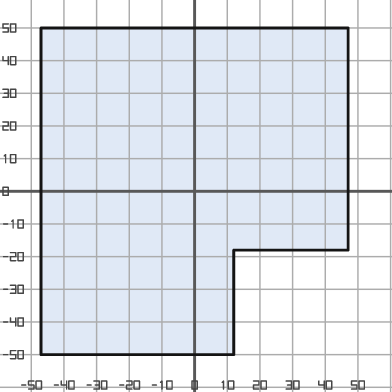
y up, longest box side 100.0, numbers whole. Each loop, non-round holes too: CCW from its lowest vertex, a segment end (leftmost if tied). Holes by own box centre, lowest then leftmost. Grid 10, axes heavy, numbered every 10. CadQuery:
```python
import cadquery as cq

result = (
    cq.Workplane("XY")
    .moveTo(-47.0, -50.0)
    .lineTo(12.0, -50.0)
    .lineTo(12.0, -18.0)
    .lineTo(47.0, -18.0)
    .lineTo(47.0, 50.0)
    .lineTo(-47.0, 50.0)
    .close()
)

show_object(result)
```